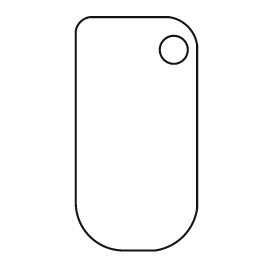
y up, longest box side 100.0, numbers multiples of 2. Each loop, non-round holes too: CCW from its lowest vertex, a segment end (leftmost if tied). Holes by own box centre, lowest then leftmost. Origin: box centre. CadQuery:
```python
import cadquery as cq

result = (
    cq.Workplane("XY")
    .moveTo(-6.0, -50.0)
    .lineTo(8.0, -50.0)
    .threePointArc((20.0, -44.0), (26.0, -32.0))
    .lineTo(26.0, 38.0)
    .threePointArc((22.0, 46.0), (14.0, 50.0))
    .lineTo(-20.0, 50.0)
    .threePointArc((-24.0, 48.0), (-26.0, 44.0))
    .lineTo(-26.0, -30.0)
    .threePointArc((-20.0, -44.0), (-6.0, -50.0))
    .close()
    .moveTo(16.0, 36.0)
    .circle(6.0)
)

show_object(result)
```